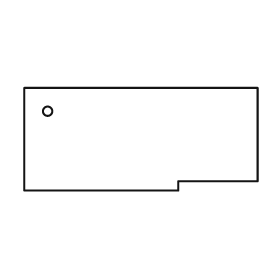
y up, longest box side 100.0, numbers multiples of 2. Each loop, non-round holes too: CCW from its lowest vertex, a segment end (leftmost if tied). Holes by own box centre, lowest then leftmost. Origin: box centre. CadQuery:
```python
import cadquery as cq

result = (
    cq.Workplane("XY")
    .moveTo(-50.0, -22.0)
    .lineTo(16.0, -22.0)
    .lineTo(16.0, -18.0)
    .lineTo(50.0, -18.0)
    .lineTo(50.0, 22.0)
    .lineTo(-50.0, 22.0)
    .close()
    .moveTo(-40.0, 12.0)
    .circle(2.0)
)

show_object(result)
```